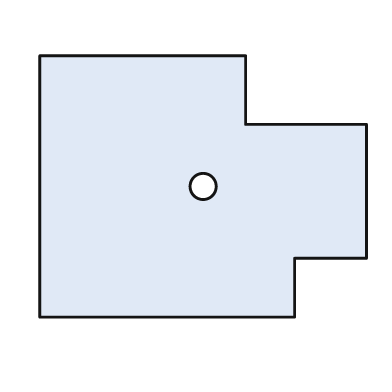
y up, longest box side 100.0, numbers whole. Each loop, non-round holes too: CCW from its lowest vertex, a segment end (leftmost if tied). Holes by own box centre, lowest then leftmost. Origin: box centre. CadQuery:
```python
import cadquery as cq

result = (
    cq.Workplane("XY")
    .moveTo(-50.0, -40.0)
    .lineTo(28.0, -40.0)
    .lineTo(28.0, -22.0)
    .lineTo(50.0, -22.0)
    .lineTo(50.0, 19.0)
    .lineTo(13.0, 19.0)
    .lineTo(13.0, 40.0)
    .lineTo(-50.0, 40.0)
    .close()
    .moveTo(0.0, 0.0)
    .circle(4.0)
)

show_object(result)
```